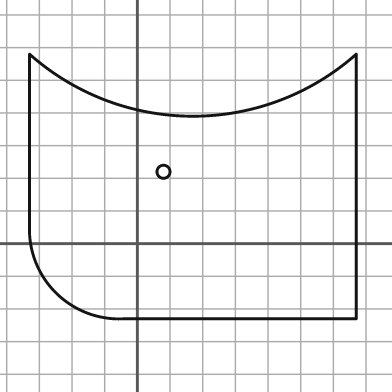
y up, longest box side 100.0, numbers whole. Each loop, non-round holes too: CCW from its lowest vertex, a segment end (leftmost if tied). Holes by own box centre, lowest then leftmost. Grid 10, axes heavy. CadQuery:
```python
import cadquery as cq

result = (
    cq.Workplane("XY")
    .moveTo(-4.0, -23.0)
    .lineTo(67.0, -23.0)
    .lineTo(67.0, 58.0)
    .threePointArc((17.0, 39.0), (-33.0, 58.0))
    .lineTo(-33.0, 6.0)
    .threePointArc((-25.0, -15.0), (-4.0, -23.0))
    .close()
    .moveTo(8.0, 22.0)
    .circle(2.0)
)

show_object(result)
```